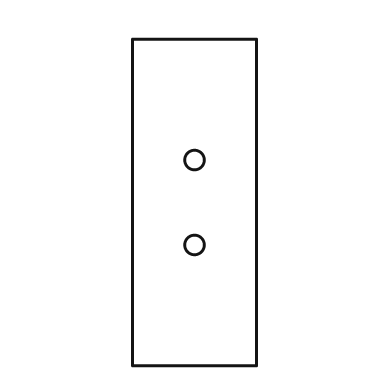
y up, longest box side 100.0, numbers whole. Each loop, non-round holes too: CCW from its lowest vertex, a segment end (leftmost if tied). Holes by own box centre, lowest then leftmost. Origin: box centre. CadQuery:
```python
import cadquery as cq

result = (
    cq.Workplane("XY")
    .moveTo(-19.0, -50.0)
    .lineTo(19.0, -50.0)
    .lineTo(19.0, 50.0)
    .lineTo(-19.0, 50.0)
    .close()
    .moveTo(0.0, -13.0)
    .circle(3.0)
    .moveTo(0.0, 13.0)
    .circle(3.0)
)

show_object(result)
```